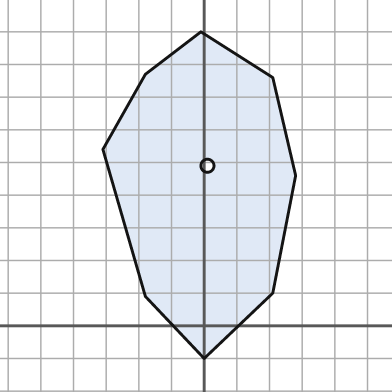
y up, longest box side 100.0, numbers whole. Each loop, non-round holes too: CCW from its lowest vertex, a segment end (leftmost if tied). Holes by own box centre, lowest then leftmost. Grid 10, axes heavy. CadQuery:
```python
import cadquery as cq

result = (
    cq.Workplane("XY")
    .moveTo(0.0, -10.0)
    .lineTo(21.0, 10.0)
    .lineTo(28.0, 46.0)
    .lineTo(21.0, 76.0)
    .lineTo(-1.0, 90.0)
    .lineTo(-18.0, 77.0)
    .lineTo(-31.0, 54.0)
    .lineTo(-18.0, 9.0)
    .close()
    .moveTo(1.0, 49.0)
    .circle(2.0)
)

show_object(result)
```